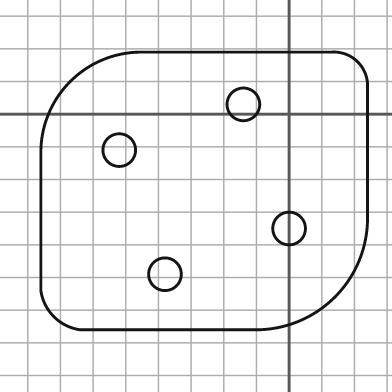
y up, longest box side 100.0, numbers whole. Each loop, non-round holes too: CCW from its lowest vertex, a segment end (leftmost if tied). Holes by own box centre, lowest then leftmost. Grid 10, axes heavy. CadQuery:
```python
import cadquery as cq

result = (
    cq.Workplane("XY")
    .moveTo(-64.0, -66.0)
    .lineTo(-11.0, -66.0)
    .threePointArc((14.0, -56.0), (24.0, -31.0))
    .lineTo(24.0, 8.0)
    .threePointArc((21.0, 16.0), (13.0, 19.0))
    .lineTo(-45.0, 19.0)
    .threePointArc((-67.0, 10.0), (-76.0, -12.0))
    .lineTo(-76.0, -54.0)
    .threePointArc((-72.0, -62.0), (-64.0, -66.0))
    .close()
    .moveTo(-38.0, -49.0)
    .circle(5.0)
    .moveTo(0.0, -35.0)
    .circle(5.0)
    .moveTo(-52.0, -11.0)
    .circle(5.0)
    .moveTo(-14.0, 3.0)
    .circle(5.0)
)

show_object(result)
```